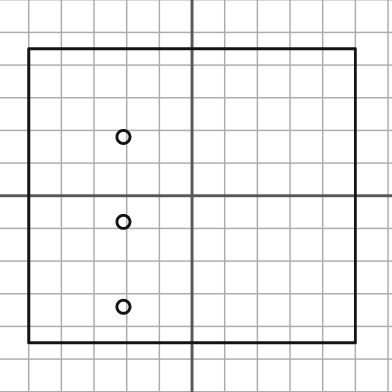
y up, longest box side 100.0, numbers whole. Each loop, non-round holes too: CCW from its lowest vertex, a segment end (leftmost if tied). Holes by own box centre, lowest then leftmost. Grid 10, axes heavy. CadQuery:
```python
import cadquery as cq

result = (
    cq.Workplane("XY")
    .moveTo(-50.0, -45.0)
    .lineTo(50.0, -45.0)
    .lineTo(50.0, 45.0)
    .lineTo(-50.0, 45.0)
    .close()
    .moveTo(-21.0, -34.0)
    .circle(2.0)
    .moveTo(-21.0, -8.0)
    .circle(2.0)
    .moveTo(-21.0, 18.0)
    .circle(2.0)
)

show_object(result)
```